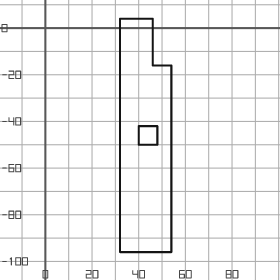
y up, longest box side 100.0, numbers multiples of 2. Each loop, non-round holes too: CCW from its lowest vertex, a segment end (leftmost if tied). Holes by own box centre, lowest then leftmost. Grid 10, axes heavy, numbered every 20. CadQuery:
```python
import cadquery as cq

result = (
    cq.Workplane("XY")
    .moveTo(32.0, -96.0)
    .lineTo(54.0, -96.0)
    .lineTo(54.0, -16.0)
    .lineTo(46.0, -16.0)
    .lineTo(46.0, 4.0)
    .lineTo(32.0, 4.0)
    .close()
    .moveTo(40.0, -50.0)
    .lineTo(48.0, -50.0)
    .lineTo(48.0, -42.0)
    .lineTo(40.0, -42.0)
    .close()
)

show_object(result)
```